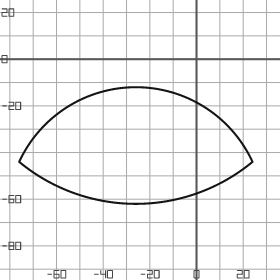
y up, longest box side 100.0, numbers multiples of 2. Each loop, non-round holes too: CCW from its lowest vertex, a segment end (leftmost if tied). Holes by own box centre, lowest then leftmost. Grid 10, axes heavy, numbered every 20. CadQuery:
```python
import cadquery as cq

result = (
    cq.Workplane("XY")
    .moveTo(-76.0, -44.0)
    .threePointArc((-26.0, -62.0), (24.0, -44.0))
    .threePointArc((-26.0, -12.0), (-76.0, -44.0))
    .close()
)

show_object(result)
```